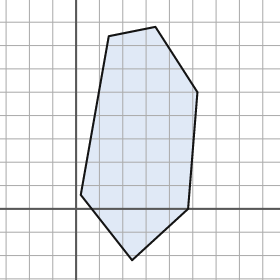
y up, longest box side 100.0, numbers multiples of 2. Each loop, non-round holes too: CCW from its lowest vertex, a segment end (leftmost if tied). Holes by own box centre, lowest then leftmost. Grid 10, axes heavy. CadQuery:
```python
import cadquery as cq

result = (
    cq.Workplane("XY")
    .moveTo(24.0, -22.0)
    .lineTo(48.0, 0.0)
    .lineTo(52.0, 50.0)
    .lineTo(34.0, 78.0)
    .lineTo(14.0, 74.0)
    .lineTo(2.0, 6.0)
    .close()
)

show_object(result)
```